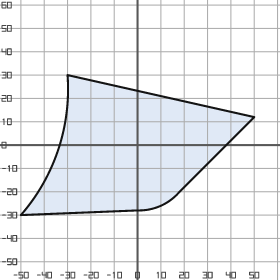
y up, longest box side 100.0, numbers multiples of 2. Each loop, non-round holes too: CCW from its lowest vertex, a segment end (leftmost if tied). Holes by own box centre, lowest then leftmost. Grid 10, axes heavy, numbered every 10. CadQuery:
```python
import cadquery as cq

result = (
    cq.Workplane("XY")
    .moveTo(-50.0, -30.0)
    .lineTo(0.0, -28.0)
    .threePointArc((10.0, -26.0), (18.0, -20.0))
    .lineTo(50.0, 12.0)
    .lineTo(-30.0, 30.0)
    .threePointArc((-34.0, -2.0), (-50.0, -30.0))
    .close()
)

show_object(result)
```